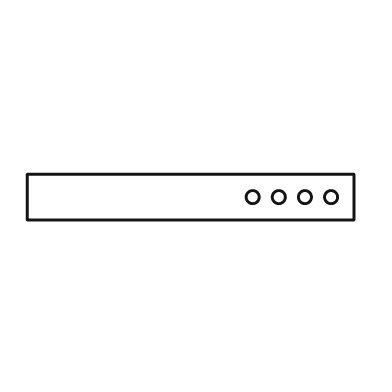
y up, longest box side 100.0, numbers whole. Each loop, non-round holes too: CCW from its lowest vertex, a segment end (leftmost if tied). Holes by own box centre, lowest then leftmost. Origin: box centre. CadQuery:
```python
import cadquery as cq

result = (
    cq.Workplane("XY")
    .moveTo(-50.0, -7.0)
    .lineTo(50.0, -7.0)
    .lineTo(50.0, 7.0)
    .lineTo(-50.0, 7.0)
    .close()
    .moveTo(19.0, 0.0)
    .circle(2.0)
    .moveTo(27.0, 0.0)
    .circle(2.0)
    .moveTo(35.0, 0.0)
    .circle(2.0)
    .moveTo(43.0, 0.0)
    .circle(2.0)
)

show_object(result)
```